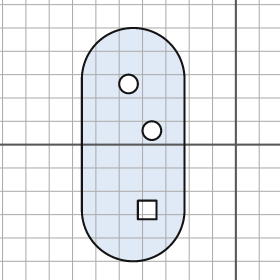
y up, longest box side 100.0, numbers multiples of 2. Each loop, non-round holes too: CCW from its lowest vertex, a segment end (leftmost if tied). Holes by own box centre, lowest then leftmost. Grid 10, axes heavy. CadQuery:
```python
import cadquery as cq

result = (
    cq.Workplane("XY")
    .moveTo(-66.0, -28.0)
    .threePointArc((-44.0, -50.0), (-22.0, -28.0))
    .lineTo(-22.0, 28.0)
    .threePointArc((-44.0, 50.0), (-66.0, 28.0))
    .close()
    .moveTo(-42.0, -32.0)
    .lineTo(-34.0, -32.0)
    .lineTo(-34.0, -24.0)
    .lineTo(-42.0, -24.0)
    .close()
    .moveTo(-36.0, 6.0)
    .circle(4.0)
    .moveTo(-46.0, 26.0)
    .circle(4.0)
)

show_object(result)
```